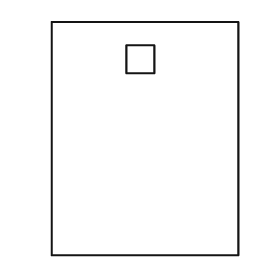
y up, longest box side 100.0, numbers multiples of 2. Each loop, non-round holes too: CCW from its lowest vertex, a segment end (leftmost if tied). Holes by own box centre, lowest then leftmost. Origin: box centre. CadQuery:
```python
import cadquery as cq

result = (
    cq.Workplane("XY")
    .moveTo(-40.0, -50.0)
    .lineTo(40.0, -50.0)
    .lineTo(40.0, 50.0)
    .lineTo(-40.0, 50.0)
    .close()
    .moveTo(-8.0, 28.0)
    .lineTo(4.0, 28.0)
    .lineTo(4.0, 40.0)
    .lineTo(-8.0, 40.0)
    .close()
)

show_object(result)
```